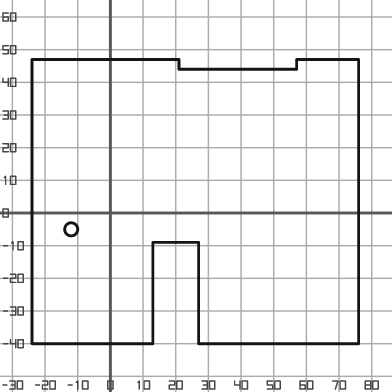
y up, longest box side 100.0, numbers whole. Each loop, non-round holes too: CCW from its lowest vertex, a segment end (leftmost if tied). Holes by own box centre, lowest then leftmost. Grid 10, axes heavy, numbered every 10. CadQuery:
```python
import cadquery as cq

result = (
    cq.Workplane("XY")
    .moveTo(-24.0, -40.0)
    .lineTo(13.0, -40.0)
    .lineTo(13.0, -9.0)
    .lineTo(27.0, -9.0)
    .lineTo(27.0, -40.0)
    .lineTo(76.0, -40.0)
    .lineTo(76.0, 47.0)
    .lineTo(57.0, 47.0)
    .lineTo(57.0, 44.0)
    .lineTo(21.0, 44.0)
    .lineTo(21.0, 47.0)
    .lineTo(-24.0, 47.0)
    .close()
    .moveTo(-12.0, -5.0)
    .circle(2.0)
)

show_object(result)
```